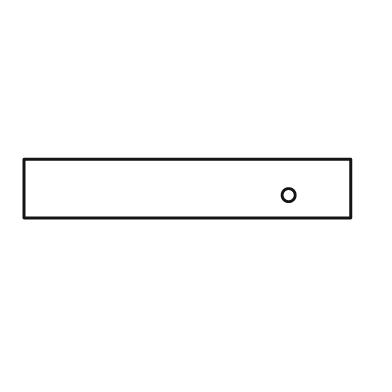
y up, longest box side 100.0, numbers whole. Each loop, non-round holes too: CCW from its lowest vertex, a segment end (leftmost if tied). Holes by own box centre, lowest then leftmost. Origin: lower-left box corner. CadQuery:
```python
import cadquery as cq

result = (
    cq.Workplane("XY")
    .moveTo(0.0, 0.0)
    .lineTo(100.0, 0.0)
    .lineTo(100.0, 18.0)
    .lineTo(0.0, 18.0)
    .close()
    .moveTo(81.0, 7.0)
    .circle(2.0)
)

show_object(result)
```